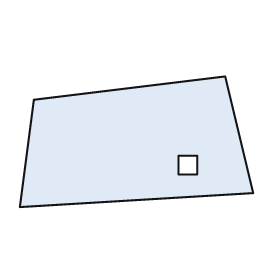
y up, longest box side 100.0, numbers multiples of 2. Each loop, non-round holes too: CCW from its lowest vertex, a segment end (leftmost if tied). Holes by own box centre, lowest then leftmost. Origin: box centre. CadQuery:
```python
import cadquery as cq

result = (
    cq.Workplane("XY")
    .moveTo(-50.0, -28.0)
    .lineTo(50.0, -22.0)
    .lineTo(38.0, 28.0)
    .lineTo(-44.0, 18.0)
    .close()
    .moveTo(18.0, -14.0)
    .lineTo(26.0, -14.0)
    .lineTo(26.0, -6.0)
    .lineTo(18.0, -6.0)
    .close()
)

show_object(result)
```